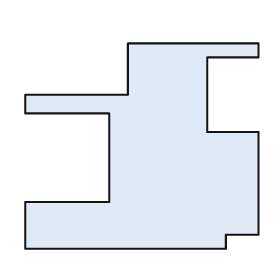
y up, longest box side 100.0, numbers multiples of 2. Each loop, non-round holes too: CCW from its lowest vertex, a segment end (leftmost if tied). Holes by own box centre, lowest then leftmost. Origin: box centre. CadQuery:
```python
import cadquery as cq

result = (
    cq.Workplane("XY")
    .moveTo(-50.0, -44.0)
    .lineTo(36.0, -44.0)
    .lineTo(36.0, -38.0)
    .lineTo(50.0, -38.0)
    .lineTo(50.0, 6.0)
    .lineTo(28.0, 6.0)
    .lineTo(28.0, 38.0)
    .lineTo(50.0, 38.0)
    .lineTo(50.0, 44.0)
    .lineTo(-6.0, 44.0)
    .lineTo(-6.0, 22.0)
    .lineTo(-50.0, 22.0)
    .lineTo(-50.0, 14.0)
    .lineTo(-14.0, 14.0)
    .lineTo(-14.0, -24.0)
    .lineTo(-50.0, -24.0)
    .close()
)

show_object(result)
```